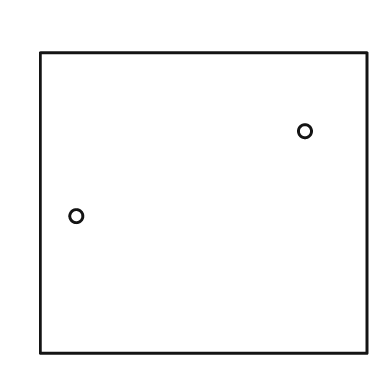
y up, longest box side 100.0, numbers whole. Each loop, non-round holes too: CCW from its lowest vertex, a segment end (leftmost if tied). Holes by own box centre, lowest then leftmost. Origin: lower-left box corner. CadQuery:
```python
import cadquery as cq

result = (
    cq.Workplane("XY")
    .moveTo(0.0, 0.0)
    .lineTo(100.0, 0.0)
    .lineTo(100.0, 92.0)
    .lineTo(0.0, 92.0)
    .close()
    .moveTo(11.0, 42.0)
    .circle(2.0)
    .moveTo(81.0, 68.0)
    .circle(2.0)
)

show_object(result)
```